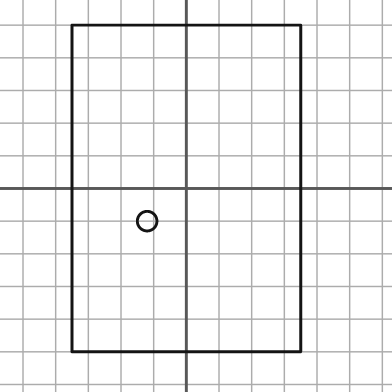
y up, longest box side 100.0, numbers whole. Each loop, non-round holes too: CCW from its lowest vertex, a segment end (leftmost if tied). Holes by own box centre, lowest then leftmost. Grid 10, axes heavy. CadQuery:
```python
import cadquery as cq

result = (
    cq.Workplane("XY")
    .moveTo(-35.0, -50.0)
    .lineTo(35.0, -50.0)
    .lineTo(35.0, 50.0)
    .lineTo(-35.0, 50.0)
    .close()
    .moveTo(-12.0, -10.0)
    .circle(3.0)
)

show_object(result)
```